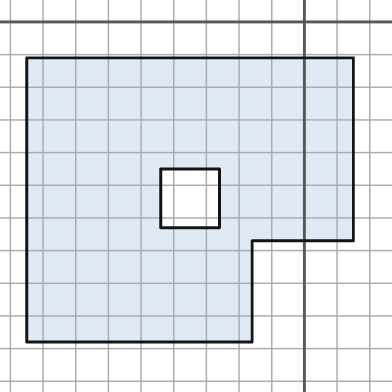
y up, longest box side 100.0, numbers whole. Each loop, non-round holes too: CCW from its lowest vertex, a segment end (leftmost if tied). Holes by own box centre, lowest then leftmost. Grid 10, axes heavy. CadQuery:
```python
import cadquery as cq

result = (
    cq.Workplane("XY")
    .moveTo(-85.0, -98.0)
    .lineTo(-16.0, -98.0)
    .lineTo(-16.0, -67.0)
    .lineTo(15.0, -67.0)
    .lineTo(15.0, -11.0)
    .lineTo(-85.0, -11.0)
    .close()
    .moveTo(-44.0, -63.0)
    .lineTo(-26.0, -63.0)
    .lineTo(-26.0, -45.0)
    .lineTo(-44.0, -45.0)
    .close()
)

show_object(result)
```